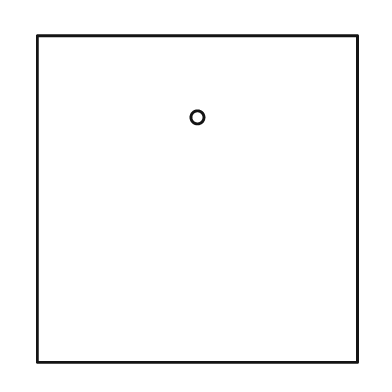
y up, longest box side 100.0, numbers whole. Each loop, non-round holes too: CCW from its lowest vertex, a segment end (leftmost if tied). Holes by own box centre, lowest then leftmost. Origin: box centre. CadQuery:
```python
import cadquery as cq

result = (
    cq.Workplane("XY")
    .moveTo(-49.0, -50.0)
    .lineTo(49.0, -50.0)
    .lineTo(49.0, 50.0)
    .lineTo(-49.0, 50.0)
    .close()
    .moveTo(0.0, 25.0)
    .circle(2.0)
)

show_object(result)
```